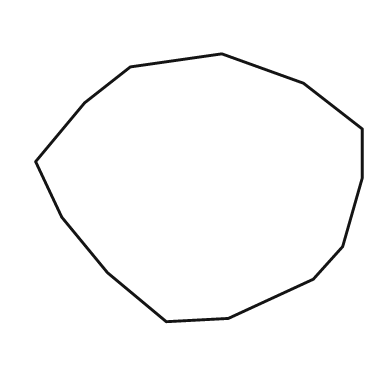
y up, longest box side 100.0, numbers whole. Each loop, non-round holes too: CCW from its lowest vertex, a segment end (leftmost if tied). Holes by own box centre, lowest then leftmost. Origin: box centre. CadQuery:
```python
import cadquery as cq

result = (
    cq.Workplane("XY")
    .moveTo(-10.0, -41.0)
    .lineTo(9.0, -40.0)
    .lineTo(35.0, -28.0)
    .lineTo(44.0, -18.0)
    .lineTo(50.0, 3.0)
    .lineTo(50.0, 18.0)
    .lineTo(32.0, 32.0)
    .lineTo(7.0, 41.0)
    .lineTo(-21.0, 37.0)
    .lineTo(-35.0, 26.0)
    .lineTo(-50.0, 8.0)
    .lineTo(-42.0, -9.0)
    .lineTo(-28.0, -26.0)
    .close()
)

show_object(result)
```